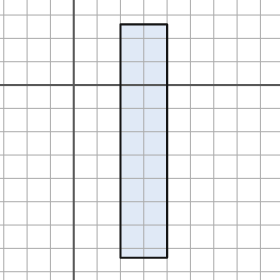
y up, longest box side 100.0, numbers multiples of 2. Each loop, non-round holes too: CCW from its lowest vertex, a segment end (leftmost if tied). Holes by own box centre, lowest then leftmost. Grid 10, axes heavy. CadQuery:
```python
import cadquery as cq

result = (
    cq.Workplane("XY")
    .moveTo(20.0, -74.0)
    .lineTo(40.0, -74.0)
    .lineTo(40.0, 26.0)
    .lineTo(20.0, 26.0)
    .close()
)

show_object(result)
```